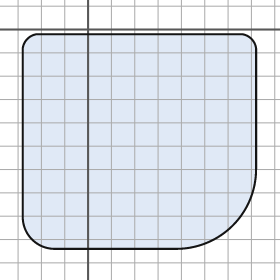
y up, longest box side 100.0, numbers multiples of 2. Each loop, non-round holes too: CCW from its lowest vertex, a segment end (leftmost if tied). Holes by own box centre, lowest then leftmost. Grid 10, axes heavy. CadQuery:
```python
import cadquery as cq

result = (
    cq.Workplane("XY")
    .moveTo(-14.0, -94.0)
    .lineTo(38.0, -94.0)
    .threePointArc((62.0, -84.0), (72.0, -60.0))
    .lineTo(72.0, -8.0)
    .threePointArc((70.0, -4.0), (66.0, -2.0))
    .lineTo(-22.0, -2.0)
    .threePointArc((-26.0, -4.0), (-28.0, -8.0))
    .lineTo(-28.0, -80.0)
    .threePointArc((-24.0, -90.0), (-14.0, -94.0))
    .close()
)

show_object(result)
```